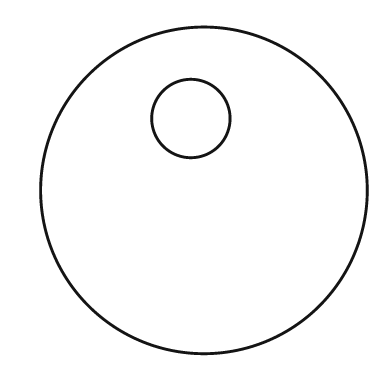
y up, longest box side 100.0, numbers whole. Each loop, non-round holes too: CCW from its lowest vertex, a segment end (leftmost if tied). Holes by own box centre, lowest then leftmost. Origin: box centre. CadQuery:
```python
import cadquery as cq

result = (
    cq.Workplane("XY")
    .moveTo(0.0, 0.0)
    .circle(50.0)
    .moveTo(-4.0, 22.0)
    .circle(12.0)
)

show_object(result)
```